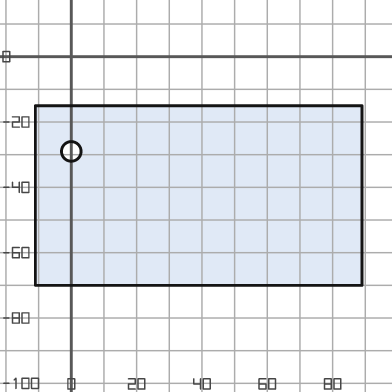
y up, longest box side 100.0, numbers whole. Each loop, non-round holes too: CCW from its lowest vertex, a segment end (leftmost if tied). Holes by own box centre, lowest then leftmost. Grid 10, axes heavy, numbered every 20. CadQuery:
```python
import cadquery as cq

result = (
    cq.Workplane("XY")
    .moveTo(-11.0, -70.0)
    .lineTo(89.0, -70.0)
    .lineTo(89.0, -15.0)
    .lineTo(-11.0, -15.0)
    .close()
    .moveTo(0.0, -29.0)
    .circle(3.0)
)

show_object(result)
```